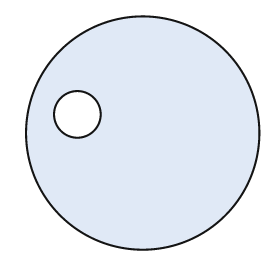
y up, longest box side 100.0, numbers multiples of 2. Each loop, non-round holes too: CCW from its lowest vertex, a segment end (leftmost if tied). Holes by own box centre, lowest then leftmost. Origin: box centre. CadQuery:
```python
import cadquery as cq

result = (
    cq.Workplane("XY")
    .moveTo(0.0, 0.0)
    .circle(50.0)
    .moveTo(-28.0, 8.0)
    .circle(10.0)
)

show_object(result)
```